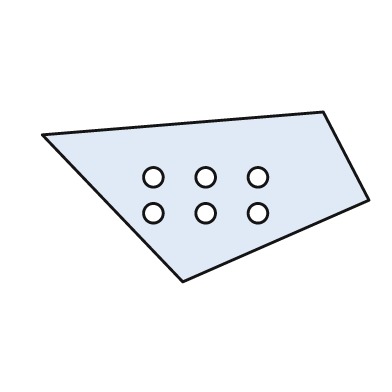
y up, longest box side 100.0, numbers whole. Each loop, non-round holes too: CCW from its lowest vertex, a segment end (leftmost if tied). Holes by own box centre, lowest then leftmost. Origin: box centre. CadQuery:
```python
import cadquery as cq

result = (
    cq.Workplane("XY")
    .moveTo(-7.0, -26.0)
    .lineTo(50.0, -1.0)
    .lineTo(36.0, 26.0)
    .lineTo(-50.0, 19.0)
    .close()
    .moveTo(-16.0, -5.0)
    .circle(3.0)
    .moveTo(0.0, -5.0)
    .circle(3.0)
    .moveTo(16.0, -5.0)
    .circle(3.0)
    .moveTo(-16.0, 6.0)
    .circle(3.0)
    .moveTo(0.0, 6.0)
    .circle(3.0)
    .moveTo(16.0, 6.0)
    .circle(3.0)
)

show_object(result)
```